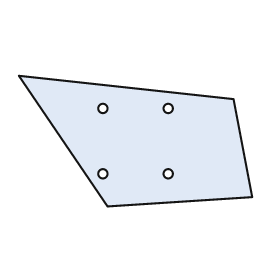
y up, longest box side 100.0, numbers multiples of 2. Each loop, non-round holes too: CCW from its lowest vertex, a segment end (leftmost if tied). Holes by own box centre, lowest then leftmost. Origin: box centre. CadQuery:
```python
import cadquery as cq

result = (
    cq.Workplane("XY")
    .moveTo(-12.0, -28.0)
    .lineTo(50.0, -24.0)
    .lineTo(42.0, 18.0)
    .lineTo(-50.0, 28.0)
    .close()
    .moveTo(-14.0, -14.0)
    .circle(2.0)
    .moveTo(14.0, -14.0)
    .circle(2.0)
    .moveTo(-14.0, 14.0)
    .circle(2.0)
    .moveTo(14.0, 14.0)
    .circle(2.0)
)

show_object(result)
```